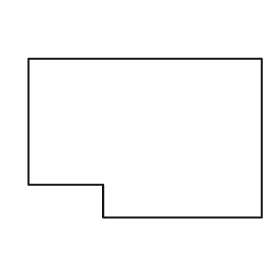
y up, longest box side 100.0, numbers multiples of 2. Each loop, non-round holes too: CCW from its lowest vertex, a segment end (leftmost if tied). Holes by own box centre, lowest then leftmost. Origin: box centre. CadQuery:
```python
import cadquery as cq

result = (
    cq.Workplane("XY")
    .moveTo(-18.0, -34.0)
    .lineTo(50.0, -34.0)
    .lineTo(50.0, 34.0)
    .lineTo(-50.0, 34.0)
    .lineTo(-50.0, -20.0)
    .lineTo(-18.0, -20.0)
    .close()
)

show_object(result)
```